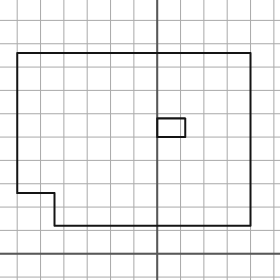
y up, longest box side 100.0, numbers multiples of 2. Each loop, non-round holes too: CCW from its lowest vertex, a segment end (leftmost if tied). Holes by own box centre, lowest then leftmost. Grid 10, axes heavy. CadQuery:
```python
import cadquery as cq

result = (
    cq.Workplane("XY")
    .moveTo(-44.0, 12.0)
    .lineTo(40.0, 12.0)
    .lineTo(40.0, 86.0)
    .lineTo(-60.0, 86.0)
    .lineTo(-60.0, 26.0)
    .lineTo(-44.0, 26.0)
    .close()
    .moveTo(0.0, 50.0)
    .lineTo(12.0, 50.0)
    .lineTo(12.0, 58.0)
    .lineTo(0.0, 58.0)
    .close()
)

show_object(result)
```